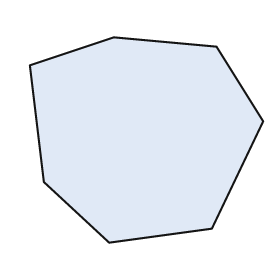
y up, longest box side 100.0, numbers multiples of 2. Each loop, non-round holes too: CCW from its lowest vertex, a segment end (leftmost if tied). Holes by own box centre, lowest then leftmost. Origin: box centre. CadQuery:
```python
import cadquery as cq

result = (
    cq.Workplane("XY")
    .moveTo(-16.0, -44.0)
    .lineTo(28.0, -38.0)
    .lineTo(50.0, 8.0)
    .lineTo(30.0, 40.0)
    .lineTo(-14.0, 44.0)
    .lineTo(-50.0, 32.0)
    .lineTo(-44.0, -18.0)
    .close()
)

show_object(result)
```